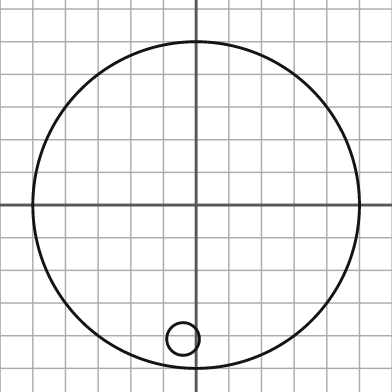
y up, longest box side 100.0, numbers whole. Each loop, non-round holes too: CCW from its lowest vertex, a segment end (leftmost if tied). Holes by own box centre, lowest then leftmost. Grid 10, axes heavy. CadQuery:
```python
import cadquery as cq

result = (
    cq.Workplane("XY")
    .moveTo(0.0, 0.0)
    .circle(50.0)
    .moveTo(-4.0, -41.0)
    .circle(5.0)
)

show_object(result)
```